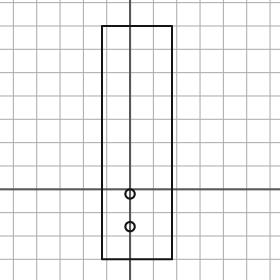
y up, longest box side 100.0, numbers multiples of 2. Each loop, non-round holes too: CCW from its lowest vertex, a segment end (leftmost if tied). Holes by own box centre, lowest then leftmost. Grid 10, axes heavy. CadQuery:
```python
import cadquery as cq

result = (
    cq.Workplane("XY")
    .moveTo(-12.0, -30.0)
    .lineTo(18.0, -30.0)
    .lineTo(18.0, 70.0)
    .lineTo(-12.0, 70.0)
    .close()
    .moveTo(0.0, -16.0)
    .circle(2.0)
    .moveTo(0.0, -2.0)
    .circle(2.0)
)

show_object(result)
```